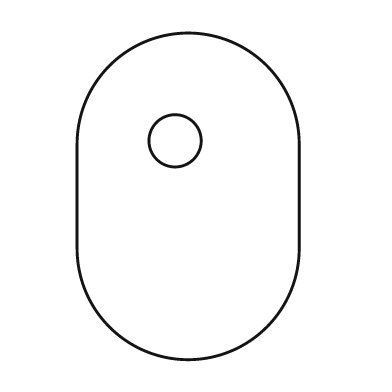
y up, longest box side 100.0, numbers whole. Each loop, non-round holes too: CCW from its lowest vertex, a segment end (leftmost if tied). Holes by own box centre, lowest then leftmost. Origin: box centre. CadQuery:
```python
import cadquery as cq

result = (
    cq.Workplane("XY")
    .moveTo(-34.0, -16.0)
    .threePointArc((0.0, -50.0), (34.0, -16.0))
    .lineTo(34.0, 16.0)
    .threePointArc((0.0, 50.0), (-34.0, 16.0))
    .close()
    .moveTo(-4.0, 17.0)
    .circle(8.0)
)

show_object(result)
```